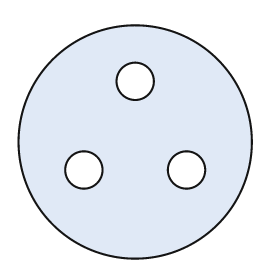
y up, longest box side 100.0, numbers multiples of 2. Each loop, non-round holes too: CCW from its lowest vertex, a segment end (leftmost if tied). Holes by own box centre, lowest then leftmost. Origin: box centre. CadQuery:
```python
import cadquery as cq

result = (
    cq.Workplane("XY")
    .moveTo(0.0, 0.0)
    .circle(50.0)
    .moveTo(-22.0, -12.0)
    .circle(8.0)
    .moveTo(22.0, -12.0)
    .circle(8.0)
    .moveTo(0.0, 26.0)
    .circle(8.0)
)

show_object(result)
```